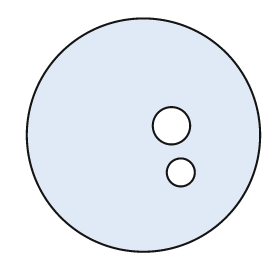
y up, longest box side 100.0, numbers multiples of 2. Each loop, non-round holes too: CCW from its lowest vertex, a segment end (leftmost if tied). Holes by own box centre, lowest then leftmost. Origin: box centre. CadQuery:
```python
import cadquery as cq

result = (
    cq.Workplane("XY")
    .moveTo(0.0, 0.0)
    .circle(50.0)
    .moveTo(16.0, -16.0)
    .circle(6.0)
    .moveTo(12.0, 4.0)
    .circle(8.0)
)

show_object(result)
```